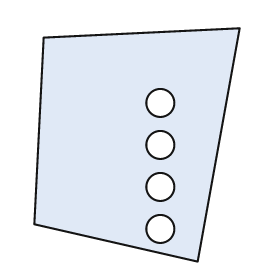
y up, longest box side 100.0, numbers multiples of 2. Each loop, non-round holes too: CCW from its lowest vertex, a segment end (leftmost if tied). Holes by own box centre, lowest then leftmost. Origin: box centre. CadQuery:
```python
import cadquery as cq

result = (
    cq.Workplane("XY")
    .moveTo(26.0, -50.0)
    .lineTo(44.0, 50.0)
    .lineTo(-40.0, 46.0)
    .lineTo(-44.0, -34.0)
    .close()
    .moveTo(10.0, -36.0)
    .circle(6.0)
    .moveTo(10.0, -18.0)
    .circle(6.0)
    .moveTo(10.0, 0.0)
    .circle(6.0)
    .moveTo(10.0, 18.0)
    .circle(6.0)
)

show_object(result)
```